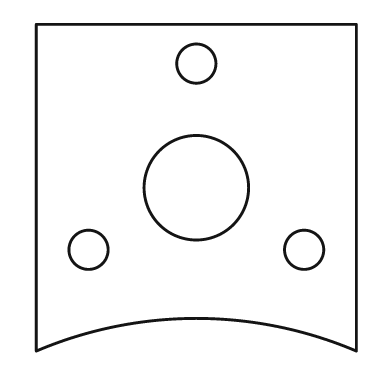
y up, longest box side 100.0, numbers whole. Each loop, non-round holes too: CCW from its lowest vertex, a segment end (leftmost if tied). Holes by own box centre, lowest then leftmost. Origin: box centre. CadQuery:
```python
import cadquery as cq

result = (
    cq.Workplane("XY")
    .moveTo(-49.0, -50.0)
    .threePointArc((0.0, -40.0), (49.0, -50.0))
    .lineTo(49.0, 50.0)
    .lineTo(-49.0, 50.0)
    .close()
    .moveTo(-33.0, -19.0)
    .circle(6.0)
    .moveTo(33.0, -19.0)
    .circle(6.0)
    .moveTo(0.0, 0.0)
    .circle(16.0)
    .moveTo(0.0, 38.0)
    .circle(6.0)
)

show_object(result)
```